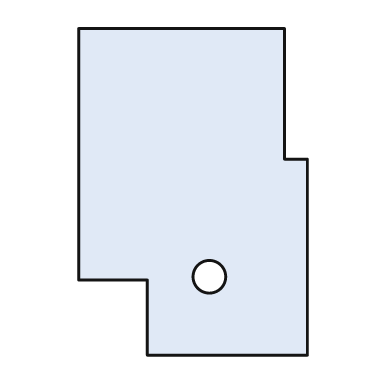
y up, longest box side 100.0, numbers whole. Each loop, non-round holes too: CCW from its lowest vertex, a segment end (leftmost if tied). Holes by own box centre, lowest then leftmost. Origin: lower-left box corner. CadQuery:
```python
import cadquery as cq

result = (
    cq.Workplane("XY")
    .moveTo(21.0, 0.0)
    .lineTo(70.0, 0.0)
    .lineTo(70.0, 60.0)
    .lineTo(63.0, 60.0)
    .lineTo(63.0, 100.0)
    .lineTo(0.0, 100.0)
    .lineTo(0.0, 23.0)
    .lineTo(21.0, 23.0)
    .close()
    .moveTo(40.0, 24.0)
    .circle(5.0)
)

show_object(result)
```